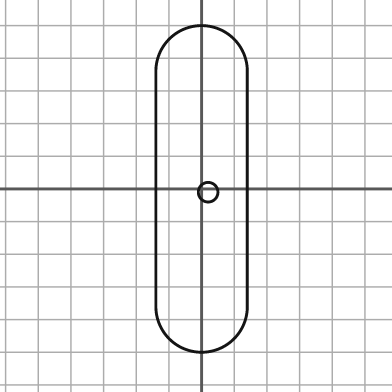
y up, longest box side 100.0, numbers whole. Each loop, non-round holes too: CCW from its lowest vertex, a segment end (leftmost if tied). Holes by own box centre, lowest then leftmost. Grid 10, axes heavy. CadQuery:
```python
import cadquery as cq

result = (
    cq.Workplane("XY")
    .moveTo(-14.0, -36.0)
    .threePointArc((0.0, -50.0), (14.0, -36.0))
    .lineTo(14.0, 36.0)
    .threePointArc((0.0, 50.0), (-14.0, 36.0))
    .close()
    .moveTo(2.0, -1.0)
    .circle(3.0)
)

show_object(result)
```